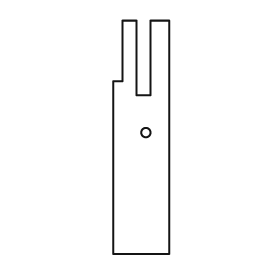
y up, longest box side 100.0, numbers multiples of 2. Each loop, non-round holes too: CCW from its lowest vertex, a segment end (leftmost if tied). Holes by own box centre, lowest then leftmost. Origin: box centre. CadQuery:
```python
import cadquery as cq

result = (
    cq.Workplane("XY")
    .moveTo(-12.0, -50.0)
    .lineTo(12.0, -50.0)
    .lineTo(12.0, 50.0)
    .lineTo(4.0, 50.0)
    .lineTo(4.0, 18.0)
    .lineTo(-2.0, 18.0)
    .lineTo(-2.0, 50.0)
    .lineTo(-8.0, 50.0)
    .lineTo(-8.0, 24.0)
    .lineTo(-12.0, 24.0)
    .close()
    .moveTo(2.0, 2.0)
    .circle(2.0)
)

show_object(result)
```